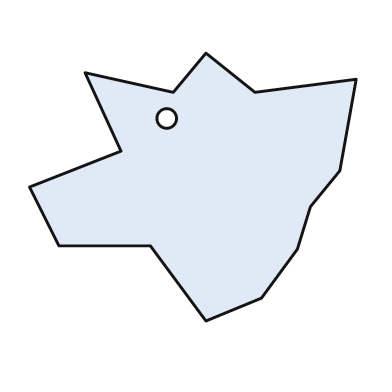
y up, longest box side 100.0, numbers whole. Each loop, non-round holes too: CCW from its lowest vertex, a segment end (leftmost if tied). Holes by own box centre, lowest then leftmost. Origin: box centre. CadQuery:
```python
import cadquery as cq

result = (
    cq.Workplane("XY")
    .moveTo(4.0, -41.0)
    .lineTo(21.0, -34.0)
    .lineTo(32.0, -19.0)
    .lineTo(36.0, -6.0)
    .lineTo(45.0, 5.0)
    .lineTo(50.0, 33.0)
    .lineTo(19.0, 29.0)
    .lineTo(4.0, 41.0)
    .lineTo(-6.0, 29.0)
    .lineTo(-33.0, 35.0)
    .lineTo(-22.0, 11.0)
    .lineTo(-50.0, 0.0)
    .lineTo(-41.0, -18.0)
    .lineTo(-13.0, -18.0)
    .close()
    .moveTo(-8.0, 21.0)
    .circle(3.0)
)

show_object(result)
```